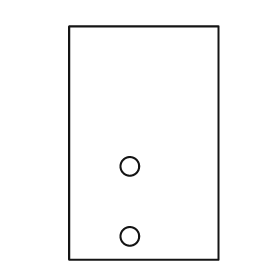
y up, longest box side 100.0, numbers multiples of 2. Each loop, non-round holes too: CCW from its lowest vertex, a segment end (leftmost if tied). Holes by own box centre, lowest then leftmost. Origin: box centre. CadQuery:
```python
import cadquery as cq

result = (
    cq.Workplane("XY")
    .moveTo(-32.0, -50.0)
    .lineTo(32.0, -50.0)
    .lineTo(32.0, 50.0)
    .lineTo(-32.0, 50.0)
    .close()
    .moveTo(-6.0, -40.0)
    .circle(4.0)
    .moveTo(-6.0, -10.0)
    .circle(4.0)
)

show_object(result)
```